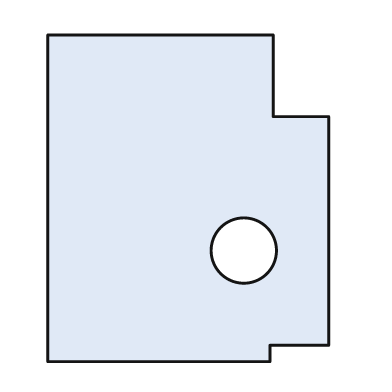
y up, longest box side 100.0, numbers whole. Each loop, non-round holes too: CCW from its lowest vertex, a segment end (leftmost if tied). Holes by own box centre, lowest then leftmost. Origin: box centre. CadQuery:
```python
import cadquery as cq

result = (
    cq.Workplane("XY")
    .moveTo(-43.0, -50.0)
    .lineTo(25.0, -50.0)
    .lineTo(25.0, -45.0)
    .lineTo(43.0, -45.0)
    .lineTo(43.0, 25.0)
    .lineTo(26.0, 25.0)
    .lineTo(26.0, 50.0)
    .lineTo(-43.0, 50.0)
    .close()
    .moveTo(17.0, -16.0)
    .circle(10.0)
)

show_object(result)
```